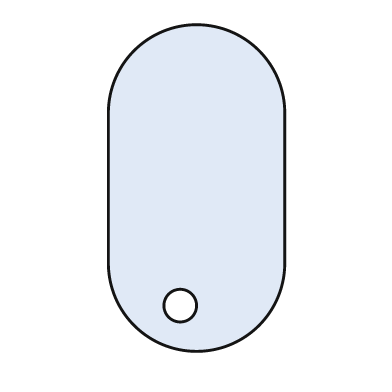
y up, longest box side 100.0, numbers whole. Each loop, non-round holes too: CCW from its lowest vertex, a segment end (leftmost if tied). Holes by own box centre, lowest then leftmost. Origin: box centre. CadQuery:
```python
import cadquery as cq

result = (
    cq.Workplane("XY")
    .moveTo(-27.0, -23.0)
    .threePointArc((0.0, -50.0), (27.0, -23.0))
    .lineTo(27.0, 23.0)
    .threePointArc((0.0, 50.0), (-27.0, 23.0))
    .close()
    .moveTo(-5.0, -36.0)
    .circle(5.0)
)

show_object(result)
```